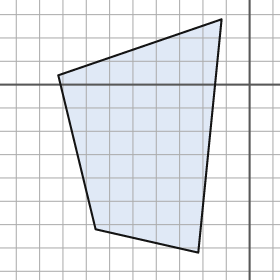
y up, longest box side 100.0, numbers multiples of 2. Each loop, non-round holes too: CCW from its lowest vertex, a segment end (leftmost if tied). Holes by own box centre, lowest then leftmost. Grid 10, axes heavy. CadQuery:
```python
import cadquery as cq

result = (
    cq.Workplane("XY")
    .moveTo(-22.0, -72.0)
    .lineTo(-12.0, 28.0)
    .lineTo(-82.0, 4.0)
    .lineTo(-66.0, -62.0)
    .close()
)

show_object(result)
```